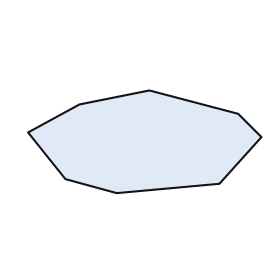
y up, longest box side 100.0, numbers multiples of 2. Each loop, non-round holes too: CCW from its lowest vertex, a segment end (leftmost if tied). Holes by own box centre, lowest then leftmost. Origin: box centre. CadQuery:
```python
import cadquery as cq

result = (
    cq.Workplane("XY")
    .moveTo(-12.0, -22.0)
    .lineTo(32.0, -18.0)
    .lineTo(50.0, 2.0)
    .lineTo(40.0, 12.0)
    .lineTo(2.0, 22.0)
    .lineTo(-28.0, 16.0)
    .lineTo(-50.0, 4.0)
    .lineTo(-34.0, -16.0)
    .close()
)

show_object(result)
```